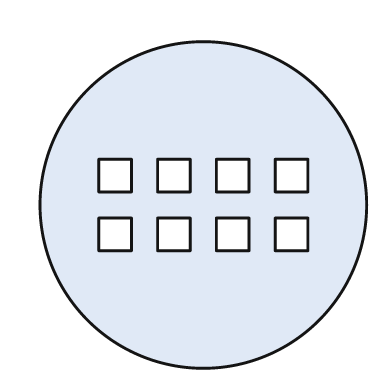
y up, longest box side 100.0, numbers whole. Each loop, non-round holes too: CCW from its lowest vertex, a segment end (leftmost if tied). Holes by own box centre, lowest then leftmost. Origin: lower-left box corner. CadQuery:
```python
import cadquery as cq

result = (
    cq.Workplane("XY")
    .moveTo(50.0, 50.0)
    .circle(50.0)
    .moveTo(18.0, 36.0)
    .lineTo(28.0, 36.0)
    .lineTo(28.0, 46.0)
    .lineTo(18.0, 46.0)
    .close()
    .moveTo(36.0, 36.0)
    .lineTo(46.0, 36.0)
    .lineTo(46.0, 46.0)
    .lineTo(36.0, 46.0)
    .close()
    .moveTo(54.0, 36.0)
    .lineTo(64.0, 36.0)
    .lineTo(64.0, 46.0)
    .lineTo(54.0, 46.0)
    .close()
    .moveTo(72.0, 36.0)
    .lineTo(82.0, 36.0)
    .lineTo(82.0, 46.0)
    .lineTo(72.0, 46.0)
    .close()
    .moveTo(18.0, 54.0)
    .lineTo(28.0, 54.0)
    .lineTo(28.0, 64.0)
    .lineTo(18.0, 64.0)
    .close()
    .moveTo(36.0, 54.0)
    .lineTo(46.0, 54.0)
    .lineTo(46.0, 64.0)
    .lineTo(36.0, 64.0)
    .close()
    .moveTo(54.0, 54.0)
    .lineTo(64.0, 54.0)
    .lineTo(64.0, 64.0)
    .lineTo(54.0, 64.0)
    .close()
    .moveTo(72.0, 54.0)
    .lineTo(82.0, 54.0)
    .lineTo(82.0, 64.0)
    .lineTo(72.0, 64.0)
    .close()
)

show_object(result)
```